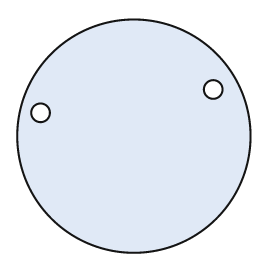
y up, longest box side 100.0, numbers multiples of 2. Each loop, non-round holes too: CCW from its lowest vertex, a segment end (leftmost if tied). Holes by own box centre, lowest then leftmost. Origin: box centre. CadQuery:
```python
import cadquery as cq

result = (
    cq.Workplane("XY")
    .moveTo(0.0, 0.0)
    .circle(50.0)
    .moveTo(-40.0, 10.0)
    .circle(4.0)
    .moveTo(34.0, 20.0)
    .circle(4.0)
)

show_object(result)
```